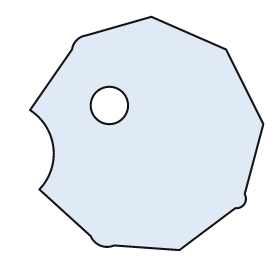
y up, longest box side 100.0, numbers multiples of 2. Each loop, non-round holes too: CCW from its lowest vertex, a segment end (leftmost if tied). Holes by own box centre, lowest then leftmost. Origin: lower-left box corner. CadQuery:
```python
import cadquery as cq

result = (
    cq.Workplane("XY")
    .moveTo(64.0, 0.0)
    .lineTo(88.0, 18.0)
    .threePointArc((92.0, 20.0), (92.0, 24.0))
    .lineTo(100.0, 54.0)
    .lineTo(84.0, 86.0)
    .lineTo(52.0, 100.0)
    .lineTo(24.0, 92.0)
    .threePointArc((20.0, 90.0), (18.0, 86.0))
    .lineTo(0.0, 60.0)
    .threePointArc((10.0, 44.0), (4.0, 26.0))
    .lineTo(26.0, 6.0)
    .threePointArc((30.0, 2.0), (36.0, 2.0))
    .close()
    .moveTo(34.0, 62.0)
    .circle(8.0)
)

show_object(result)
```